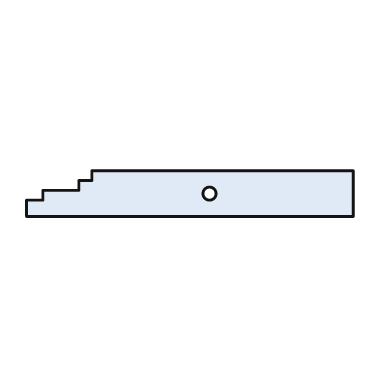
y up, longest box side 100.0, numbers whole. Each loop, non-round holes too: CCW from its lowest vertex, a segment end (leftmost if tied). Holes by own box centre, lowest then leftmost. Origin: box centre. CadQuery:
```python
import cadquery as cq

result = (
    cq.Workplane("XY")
    .moveTo(-50.0, -7.0)
    .lineTo(50.0, -7.0)
    .lineTo(50.0, 7.0)
    .lineTo(-30.0, 7.0)
    .lineTo(-30.0, 4.0)
    .lineTo(-34.0, 4.0)
    .lineTo(-34.0, 1.0)
    .lineTo(-45.0, 1.0)
    .lineTo(-45.0, -2.0)
    .lineTo(-50.0, -2.0)
    .close()
    .moveTo(6.0, 0.0)
    .circle(2.0)
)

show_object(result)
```